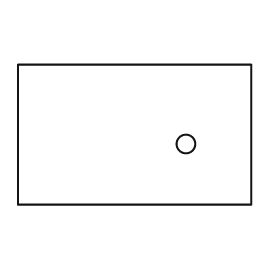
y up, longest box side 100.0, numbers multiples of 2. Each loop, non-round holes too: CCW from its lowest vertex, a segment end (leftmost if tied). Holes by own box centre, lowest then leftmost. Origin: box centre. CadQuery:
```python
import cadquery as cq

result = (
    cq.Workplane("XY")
    .moveTo(-50.0, -30.0)
    .lineTo(50.0, -30.0)
    .lineTo(50.0, 30.0)
    .lineTo(-50.0, 30.0)
    .close()
    .moveTo(22.0, -4.0)
    .circle(4.0)
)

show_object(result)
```